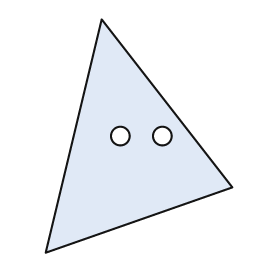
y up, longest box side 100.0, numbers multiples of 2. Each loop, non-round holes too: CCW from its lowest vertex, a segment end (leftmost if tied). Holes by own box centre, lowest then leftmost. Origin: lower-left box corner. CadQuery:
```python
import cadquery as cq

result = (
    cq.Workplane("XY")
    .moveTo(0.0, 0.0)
    .lineTo(80.0, 28.0)
    .lineTo(24.0, 100.0)
    .close()
    .moveTo(32.0, 50.0)
    .circle(4.0)
    .moveTo(50.0, 50.0)
    .circle(4.0)
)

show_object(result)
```